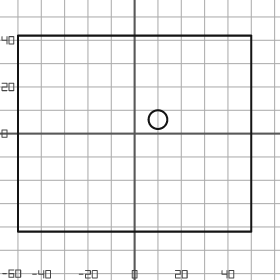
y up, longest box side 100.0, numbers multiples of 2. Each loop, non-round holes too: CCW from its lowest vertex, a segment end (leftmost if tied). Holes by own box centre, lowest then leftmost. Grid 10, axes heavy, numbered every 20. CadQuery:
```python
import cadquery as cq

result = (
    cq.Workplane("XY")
    .moveTo(-50.0, -42.0)
    .lineTo(50.0, -42.0)
    .lineTo(50.0, 42.0)
    .lineTo(-50.0, 42.0)
    .close()
    .moveTo(10.0, 6.0)
    .circle(4.0)
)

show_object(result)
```